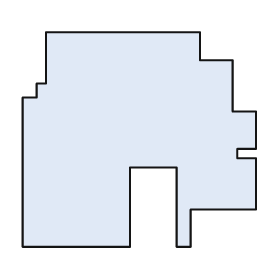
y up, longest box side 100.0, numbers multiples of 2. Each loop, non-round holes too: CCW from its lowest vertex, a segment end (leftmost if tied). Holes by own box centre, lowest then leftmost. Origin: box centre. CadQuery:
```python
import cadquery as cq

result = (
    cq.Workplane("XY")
    .moveTo(-50.0, -46.0)
    .lineTo(-4.0, -46.0)
    .lineTo(-4.0, -12.0)
    .lineTo(16.0, -12.0)
    .lineTo(16.0, -46.0)
    .lineTo(22.0, -46.0)
    .lineTo(22.0, -30.0)
    .lineTo(50.0, -30.0)
    .lineTo(50.0, -8.0)
    .lineTo(42.0, -8.0)
    .lineTo(42.0, -4.0)
    .lineTo(50.0, -4.0)
    .lineTo(50.0, 12.0)
    .lineTo(40.0, 12.0)
    .lineTo(40.0, 34.0)
    .lineTo(26.0, 34.0)
    .lineTo(26.0, 46.0)
    .lineTo(-40.0, 46.0)
    .lineTo(-40.0, 24.0)
    .lineTo(-44.0, 24.0)
    .lineTo(-44.0, 18.0)
    .lineTo(-50.0, 18.0)
    .close()
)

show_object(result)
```